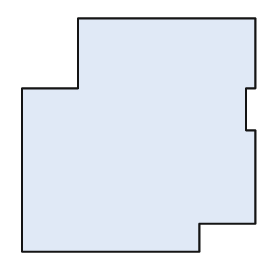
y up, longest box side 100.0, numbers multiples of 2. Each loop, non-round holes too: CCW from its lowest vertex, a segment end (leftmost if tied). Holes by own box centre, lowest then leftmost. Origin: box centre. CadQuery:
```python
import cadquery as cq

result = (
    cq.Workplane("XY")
    .moveTo(-50.0, -50.0)
    .lineTo(26.0, -50.0)
    .lineTo(26.0, -38.0)
    .lineTo(50.0, -38.0)
    .lineTo(50.0, 2.0)
    .lineTo(46.0, 2.0)
    .lineTo(46.0, 20.0)
    .lineTo(50.0, 20.0)
    .lineTo(50.0, 50.0)
    .lineTo(-26.0, 50.0)
    .lineTo(-26.0, 20.0)
    .lineTo(-50.0, 20.0)
    .close()
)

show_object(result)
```